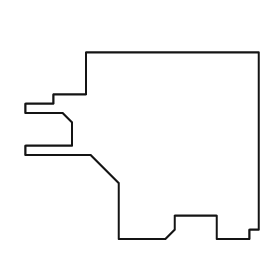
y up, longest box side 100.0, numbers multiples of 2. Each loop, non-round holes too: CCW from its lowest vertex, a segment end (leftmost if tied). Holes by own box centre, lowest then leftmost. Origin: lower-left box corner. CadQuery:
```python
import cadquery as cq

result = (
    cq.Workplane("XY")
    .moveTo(40.0, 0.0)
    .lineTo(60.0, 0.0)
    .lineTo(64.0, 4.0)
    .lineTo(64.0, 10.0)
    .lineTo(82.0, 10.0)
    .lineTo(82.0, 0.0)
    .lineTo(96.0, 0.0)
    .lineTo(96.0, 4.0)
    .lineTo(100.0, 4.0)
    .lineTo(100.0, 80.0)
    .lineTo(26.0, 80.0)
    .lineTo(26.0, 62.0)
    .lineTo(12.0, 62.0)
    .lineTo(12.0, 58.0)
    .lineTo(0.0, 58.0)
    .lineTo(0.0, 54.0)
    .lineTo(16.0, 54.0)
    .lineTo(20.0, 50.0)
    .lineTo(20.0, 40.0)
    .lineTo(0.0, 40.0)
    .lineTo(0.0, 36.0)
    .lineTo(28.0, 36.0)
    .lineTo(40.0, 24.0)
    .close()
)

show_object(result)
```